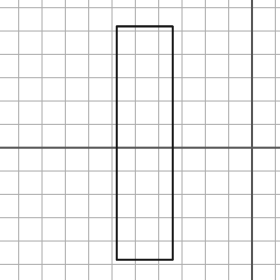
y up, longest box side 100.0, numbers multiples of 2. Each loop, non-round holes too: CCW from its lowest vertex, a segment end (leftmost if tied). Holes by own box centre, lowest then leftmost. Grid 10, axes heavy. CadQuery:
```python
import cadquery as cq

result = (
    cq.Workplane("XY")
    .moveTo(-58.0, -48.0)
    .lineTo(-34.0, -48.0)
    .lineTo(-34.0, 52.0)
    .lineTo(-58.0, 52.0)
    .close()
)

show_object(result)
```